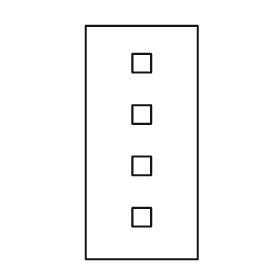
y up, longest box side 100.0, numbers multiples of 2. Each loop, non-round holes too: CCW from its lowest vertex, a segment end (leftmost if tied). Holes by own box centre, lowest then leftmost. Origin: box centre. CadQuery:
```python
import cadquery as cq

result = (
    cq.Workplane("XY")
    .moveTo(-24.0, -50.0)
    .lineTo(24.0, -50.0)
    .lineTo(24.0, 50.0)
    .lineTo(-24.0, 50.0)
    .close()
    .moveTo(-4.0, -36.0)
    .lineTo(4.0, -36.0)
    .lineTo(4.0, -28.0)
    .lineTo(-4.0, -28.0)
    .close()
    .moveTo(-4.0, -14.0)
    .lineTo(4.0, -14.0)
    .lineTo(4.0, -6.0)
    .lineTo(-4.0, -6.0)
    .close()
    .moveTo(-4.0, 8.0)
    .lineTo(4.0, 8.0)
    .lineTo(4.0, 16.0)
    .lineTo(-4.0, 16.0)
    .close()
    .moveTo(-4.0, 30.0)
    .lineTo(4.0, 30.0)
    .lineTo(4.0, 38.0)
    .lineTo(-4.0, 38.0)
    .close()
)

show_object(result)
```